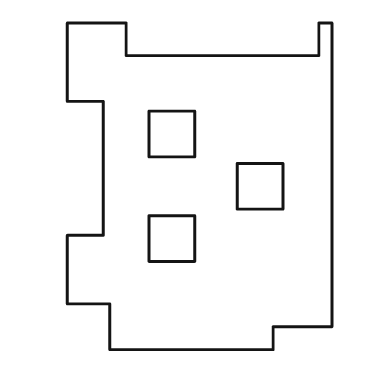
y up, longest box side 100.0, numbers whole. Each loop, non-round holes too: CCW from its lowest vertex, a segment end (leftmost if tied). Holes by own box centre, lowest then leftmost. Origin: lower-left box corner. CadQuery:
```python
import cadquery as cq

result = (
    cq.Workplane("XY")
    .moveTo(13.0, 0.0)
    .lineTo(63.0, 0.0)
    .lineTo(63.0, 7.0)
    .lineTo(81.0, 7.0)
    .lineTo(81.0, 100.0)
    .lineTo(77.0, 100.0)
    .lineTo(77.0, 90.0)
    .lineTo(18.0, 90.0)
    .lineTo(18.0, 100.0)
    .lineTo(0.0, 100.0)
    .lineTo(0.0, 76.0)
    .lineTo(11.0, 76.0)
    .lineTo(11.0, 35.0)
    .lineTo(0.0, 35.0)
    .lineTo(0.0, 14.0)
    .lineTo(13.0, 14.0)
    .close()
    .moveTo(25.0, 27.0)
    .lineTo(39.0, 27.0)
    .lineTo(39.0, 41.0)
    .lineTo(25.0, 41.0)
    .close()
    .moveTo(52.0, 43.0)
    .lineTo(66.0, 43.0)
    .lineTo(66.0, 57.0)
    .lineTo(52.0, 57.0)
    .close()
    .moveTo(25.0, 59.0)
    .lineTo(39.0, 59.0)
    .lineTo(39.0, 73.0)
    .lineTo(25.0, 73.0)
    .close()
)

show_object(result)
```